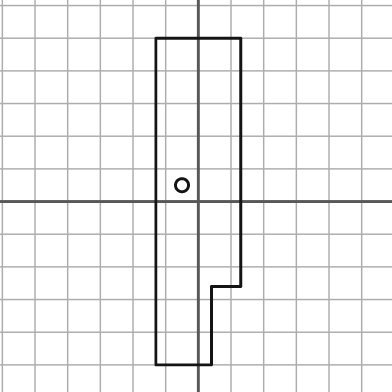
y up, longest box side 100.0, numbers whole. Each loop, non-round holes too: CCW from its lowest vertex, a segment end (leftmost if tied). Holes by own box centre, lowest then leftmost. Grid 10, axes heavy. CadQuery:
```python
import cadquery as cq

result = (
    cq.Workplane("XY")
    .moveTo(-13.0, -50.0)
    .lineTo(4.0, -50.0)
    .lineTo(4.0, -26.0)
    .lineTo(13.0, -26.0)
    .lineTo(13.0, 50.0)
    .lineTo(-13.0, 50.0)
    .close()
    .moveTo(-5.0, 5.0)
    .circle(2.0)
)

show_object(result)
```